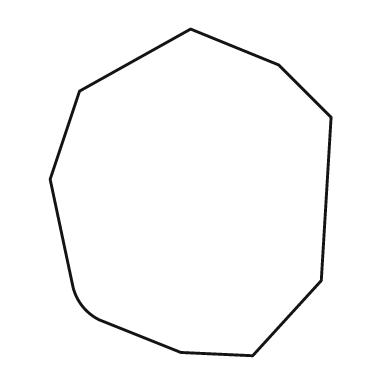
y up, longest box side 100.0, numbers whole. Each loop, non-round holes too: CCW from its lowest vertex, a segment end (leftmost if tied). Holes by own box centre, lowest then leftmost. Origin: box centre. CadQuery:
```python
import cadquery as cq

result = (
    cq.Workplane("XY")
    .moveTo(19.0, -50.0)
    .lineTo(40.0, -27.0)
    .lineTo(43.0, 23.0)
    .lineTo(27.0, 39.0)
    .lineTo(0.0, 50.0)
    .lineTo(-34.0, 31.0)
    .lineTo(-43.0, 4.0)
    .lineTo(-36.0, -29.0)
    .threePointArc((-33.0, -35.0), (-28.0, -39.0))
    .lineTo(-3.0, -49.0)
    .close()
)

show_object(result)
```